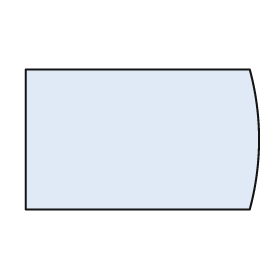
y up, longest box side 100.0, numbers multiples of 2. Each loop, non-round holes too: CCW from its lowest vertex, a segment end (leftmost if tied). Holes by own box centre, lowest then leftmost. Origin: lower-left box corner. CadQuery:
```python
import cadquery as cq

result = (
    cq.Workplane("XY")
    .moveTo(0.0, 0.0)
    .lineTo(96.0, 0.0)
    .threePointArc((100.0, 30.0), (96.0, 60.0))
    .lineTo(0.0, 60.0)
    .close()
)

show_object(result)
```